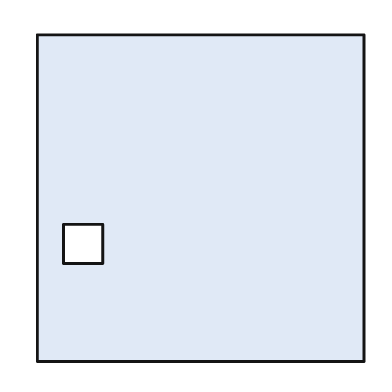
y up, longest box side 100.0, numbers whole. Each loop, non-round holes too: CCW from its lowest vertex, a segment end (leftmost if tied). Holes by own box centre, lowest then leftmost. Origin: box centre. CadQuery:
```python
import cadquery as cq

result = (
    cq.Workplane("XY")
    .moveTo(-50.0, -50.0)
    .lineTo(50.0, -50.0)
    .lineTo(50.0, 50.0)
    .lineTo(-50.0, 50.0)
    .close()
    .moveTo(-42.0, -20.0)
    .lineTo(-30.0, -20.0)
    .lineTo(-30.0, -8.0)
    .lineTo(-42.0, -8.0)
    .close()
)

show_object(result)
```